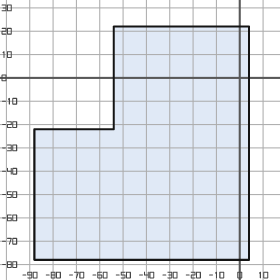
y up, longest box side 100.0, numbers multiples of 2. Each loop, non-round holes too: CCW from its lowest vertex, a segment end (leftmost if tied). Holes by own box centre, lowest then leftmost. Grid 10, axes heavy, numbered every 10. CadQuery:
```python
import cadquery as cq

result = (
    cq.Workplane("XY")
    .moveTo(-88.0, -78.0)
    .lineTo(4.0, -78.0)
    .lineTo(4.0, 22.0)
    .lineTo(-54.0, 22.0)
    .lineTo(-54.0, -22.0)
    .lineTo(-88.0, -22.0)
    .close()
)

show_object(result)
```